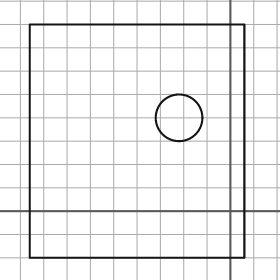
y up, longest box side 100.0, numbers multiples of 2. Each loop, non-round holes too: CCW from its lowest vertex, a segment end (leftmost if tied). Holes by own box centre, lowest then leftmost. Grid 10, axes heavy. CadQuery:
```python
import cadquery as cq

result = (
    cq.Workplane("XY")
    .moveTo(-86.0, -20.0)
    .lineTo(6.0, -20.0)
    .lineTo(6.0, 80.0)
    .lineTo(-86.0, 80.0)
    .close()
    .moveTo(-22.0, 40.0)
    .circle(10.0)
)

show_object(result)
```